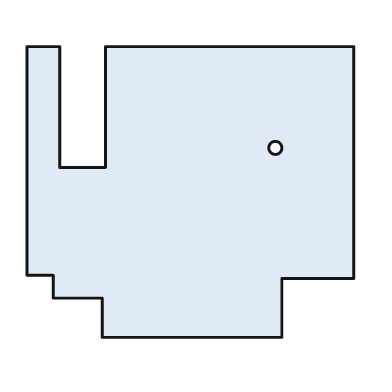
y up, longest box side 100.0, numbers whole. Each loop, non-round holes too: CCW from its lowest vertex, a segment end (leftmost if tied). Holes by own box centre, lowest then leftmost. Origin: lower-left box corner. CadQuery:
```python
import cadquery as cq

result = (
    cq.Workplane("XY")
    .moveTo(23.0, 0.0)
    .lineTo(78.0, 0.0)
    .lineTo(78.0, 18.0)
    .lineTo(100.0, 18.0)
    .lineTo(100.0, 89.0)
    .lineTo(24.0, 89.0)
    .lineTo(24.0, 52.0)
    .lineTo(10.0, 52.0)
    .lineTo(10.0, 89.0)
    .lineTo(0.0, 89.0)
    .lineTo(0.0, 19.0)
    .lineTo(8.0, 19.0)
    .lineTo(8.0, 12.0)
    .lineTo(23.0, 12.0)
    .close()
    .moveTo(76.0, 58.0)
    .circle(2.0)
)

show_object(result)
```